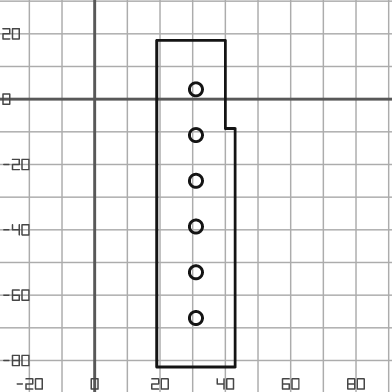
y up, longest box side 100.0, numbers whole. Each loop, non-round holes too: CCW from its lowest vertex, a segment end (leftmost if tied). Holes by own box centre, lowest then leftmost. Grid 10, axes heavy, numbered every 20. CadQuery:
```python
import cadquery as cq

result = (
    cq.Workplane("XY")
    .moveTo(19.0, -82.0)
    .lineTo(43.0, -82.0)
    .lineTo(43.0, -9.0)
    .lineTo(40.0, -9.0)
    .lineTo(40.0, 18.0)
    .lineTo(19.0, 18.0)
    .close()
    .moveTo(31.0, -67.0)
    .circle(2.0)
    .moveTo(31.0, -53.0)
    .circle(2.0)
    .moveTo(31.0, -39.0)
    .circle(2.0)
    .moveTo(31.0, -25.0)
    .circle(2.0)
    .moveTo(31.0, -11.0)
    .circle(2.0)
    .moveTo(31.0, 3.0)
    .circle(2.0)
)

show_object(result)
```